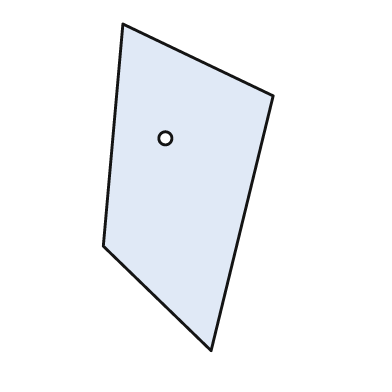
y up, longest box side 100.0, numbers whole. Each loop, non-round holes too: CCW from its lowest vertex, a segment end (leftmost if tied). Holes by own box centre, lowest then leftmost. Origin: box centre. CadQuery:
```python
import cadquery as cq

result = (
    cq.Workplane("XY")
    .moveTo(7.0, -50.0)
    .lineTo(26.0, 28.0)
    .lineTo(-20.0, 50.0)
    .lineTo(-26.0, -18.0)
    .close()
    .moveTo(-7.0, 15.0)
    .circle(2.0)
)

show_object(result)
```